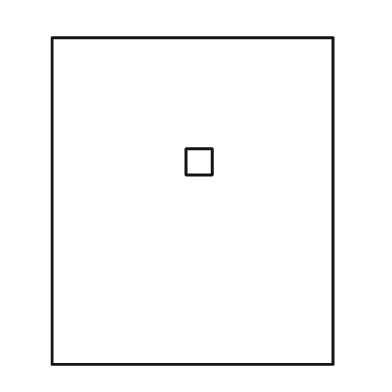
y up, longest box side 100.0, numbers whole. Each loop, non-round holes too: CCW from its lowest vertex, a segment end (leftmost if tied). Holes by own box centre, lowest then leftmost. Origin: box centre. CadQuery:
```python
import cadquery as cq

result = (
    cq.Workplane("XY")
    .moveTo(-43.0, -50.0)
    .lineTo(43.0, -50.0)
    .lineTo(43.0, 50.0)
    .lineTo(-43.0, 50.0)
    .close()
    .moveTo(-2.0, 8.0)
    .lineTo(6.0, 8.0)
    .lineTo(6.0, 16.0)
    .lineTo(-2.0, 16.0)
    .close()
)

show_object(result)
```